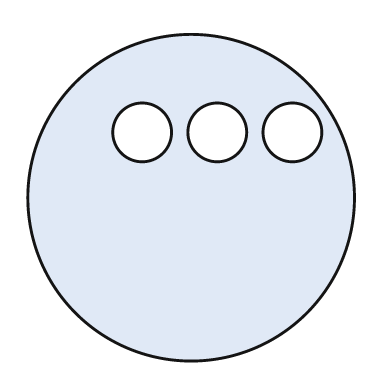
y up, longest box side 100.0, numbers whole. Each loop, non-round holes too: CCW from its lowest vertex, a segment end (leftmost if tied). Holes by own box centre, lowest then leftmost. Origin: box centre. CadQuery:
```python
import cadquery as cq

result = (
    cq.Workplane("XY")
    .moveTo(0.0, 0.0)
    .circle(50.0)
    .moveTo(-15.0, 20.0)
    .circle(9.0)
    .moveTo(8.0, 20.0)
    .circle(9.0)
    .moveTo(31.0, 20.0)
    .circle(9.0)
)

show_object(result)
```